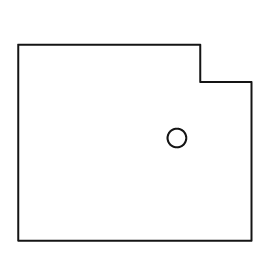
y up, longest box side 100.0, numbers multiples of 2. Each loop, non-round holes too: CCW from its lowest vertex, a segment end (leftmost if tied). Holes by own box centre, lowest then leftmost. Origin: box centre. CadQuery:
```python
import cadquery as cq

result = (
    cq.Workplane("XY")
    .moveTo(-50.0, -42.0)
    .lineTo(50.0, -42.0)
    .lineTo(50.0, 26.0)
    .lineTo(28.0, 26.0)
    .lineTo(28.0, 42.0)
    .lineTo(-50.0, 42.0)
    .close()
    .moveTo(18.0, 2.0)
    .circle(4.0)
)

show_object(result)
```